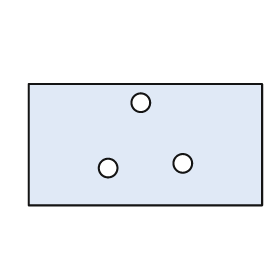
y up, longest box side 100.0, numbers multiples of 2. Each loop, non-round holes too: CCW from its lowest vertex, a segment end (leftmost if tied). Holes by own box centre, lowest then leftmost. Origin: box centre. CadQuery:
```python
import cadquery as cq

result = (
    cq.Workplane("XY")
    .moveTo(-50.0, -26.0)
    .lineTo(50.0, -26.0)
    .lineTo(50.0, 26.0)
    .lineTo(-50.0, 26.0)
    .close()
    .moveTo(-16.0, -10.0)
    .circle(4.0)
    .moveTo(16.0, -8.0)
    .circle(4.0)
    .moveTo(-2.0, 18.0)
    .circle(4.0)
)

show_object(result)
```